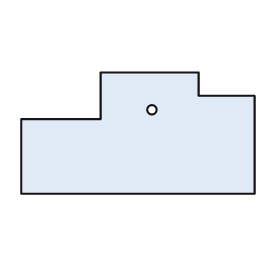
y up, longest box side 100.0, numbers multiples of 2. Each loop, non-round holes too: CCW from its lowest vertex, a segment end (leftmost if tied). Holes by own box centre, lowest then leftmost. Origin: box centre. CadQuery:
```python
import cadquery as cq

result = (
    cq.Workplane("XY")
    .moveTo(-50.0, -26.0)
    .lineTo(50.0, -26.0)
    .lineTo(50.0, 16.0)
    .lineTo(26.0, 16.0)
    .lineTo(26.0, 26.0)
    .lineTo(-16.0, 26.0)
    .lineTo(-16.0, 6.0)
    .lineTo(-50.0, 6.0)
    .close()
    .moveTo(6.0, 10.0)
    .circle(2.0)
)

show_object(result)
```